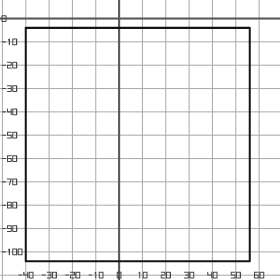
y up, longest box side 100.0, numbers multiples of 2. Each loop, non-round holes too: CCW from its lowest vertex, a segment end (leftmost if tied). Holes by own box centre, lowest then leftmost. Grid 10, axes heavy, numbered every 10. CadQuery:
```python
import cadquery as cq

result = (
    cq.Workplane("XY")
    .moveTo(-40.0, -104.0)
    .lineTo(56.0, -104.0)
    .lineTo(56.0, -4.0)
    .lineTo(-40.0, -4.0)
    .close()
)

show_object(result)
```